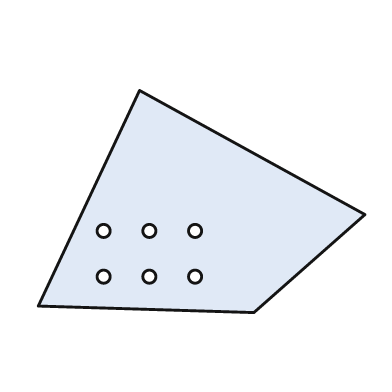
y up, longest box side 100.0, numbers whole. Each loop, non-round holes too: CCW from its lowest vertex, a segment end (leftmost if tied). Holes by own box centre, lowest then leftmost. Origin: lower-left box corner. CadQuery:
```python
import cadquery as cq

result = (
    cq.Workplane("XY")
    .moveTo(66.0, 0.0)
    .lineTo(100.0, 30.0)
    .lineTo(31.0, 68.0)
    .lineTo(0.0, 2.0)
    .close()
    .moveTo(20.0, 11.0)
    .circle(2.0)
    .moveTo(34.0, 11.0)
    .circle(2.0)
    .moveTo(48.0, 11.0)
    .circle(2.0)
    .moveTo(20.0, 25.0)
    .circle(2.0)
    .moveTo(34.0, 25.0)
    .circle(2.0)
    .moveTo(48.0, 25.0)
    .circle(2.0)
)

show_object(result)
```